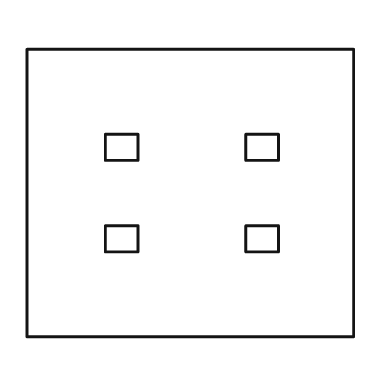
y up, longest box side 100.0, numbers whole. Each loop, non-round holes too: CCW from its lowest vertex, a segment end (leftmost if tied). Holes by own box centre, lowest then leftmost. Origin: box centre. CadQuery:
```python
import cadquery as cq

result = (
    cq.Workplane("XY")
    .moveTo(-50.0, -44.0)
    .lineTo(50.0, -44.0)
    .lineTo(50.0, 44.0)
    .lineTo(-50.0, 44.0)
    .close()
    .moveTo(-26.0, -18.0)
    .lineTo(-16.0, -18.0)
    .lineTo(-16.0, -10.0)
    .lineTo(-26.0, -10.0)
    .close()
    .moveTo(17.0, -18.0)
    .lineTo(27.0, -18.0)
    .lineTo(27.0, -10.0)
    .lineTo(17.0, -10.0)
    .close()
    .moveTo(-26.0, 10.0)
    .lineTo(-16.0, 10.0)
    .lineTo(-16.0, 18.0)
    .lineTo(-26.0, 18.0)
    .close()
    .moveTo(17.0, 10.0)
    .lineTo(27.0, 10.0)
    .lineTo(27.0, 18.0)
    .lineTo(17.0, 18.0)
    .close()
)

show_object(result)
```